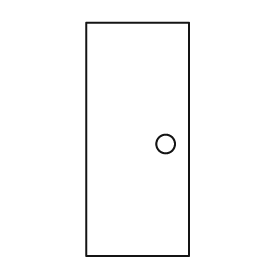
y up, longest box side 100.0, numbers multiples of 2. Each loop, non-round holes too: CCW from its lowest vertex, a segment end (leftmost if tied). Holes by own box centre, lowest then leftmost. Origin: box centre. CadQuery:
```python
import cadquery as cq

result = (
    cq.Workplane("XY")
    .moveTo(-22.0, -50.0)
    .lineTo(22.0, -50.0)
    .lineTo(22.0, 50.0)
    .lineTo(-22.0, 50.0)
    .close()
    .moveTo(12.0, -2.0)
    .circle(4.0)
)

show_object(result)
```